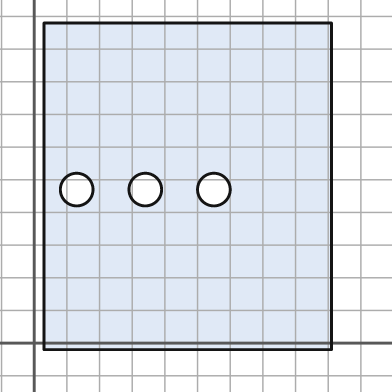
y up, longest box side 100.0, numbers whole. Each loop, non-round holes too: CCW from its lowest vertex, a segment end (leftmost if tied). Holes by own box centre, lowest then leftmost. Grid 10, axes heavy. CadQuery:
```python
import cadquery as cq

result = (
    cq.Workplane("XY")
    .moveTo(3.0, -2.0)
    .lineTo(91.0, -2.0)
    .lineTo(91.0, 98.0)
    .lineTo(3.0, 98.0)
    .close()
    .moveTo(13.0, 47.0)
    .circle(5.0)
    .moveTo(34.0, 47.0)
    .circle(5.0)
    .moveTo(55.0, 47.0)
    .circle(5.0)
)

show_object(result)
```